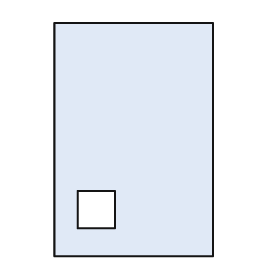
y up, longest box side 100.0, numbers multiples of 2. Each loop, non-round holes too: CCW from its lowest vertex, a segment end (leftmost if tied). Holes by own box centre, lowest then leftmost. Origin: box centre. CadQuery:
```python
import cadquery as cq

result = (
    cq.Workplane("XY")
    .moveTo(-34.0, -50.0)
    .lineTo(34.0, -50.0)
    .lineTo(34.0, 50.0)
    .lineTo(-34.0, 50.0)
    .close()
    .moveTo(-24.0, -38.0)
    .lineTo(-8.0, -38.0)
    .lineTo(-8.0, -22.0)
    .lineTo(-24.0, -22.0)
    .close()
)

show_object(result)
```